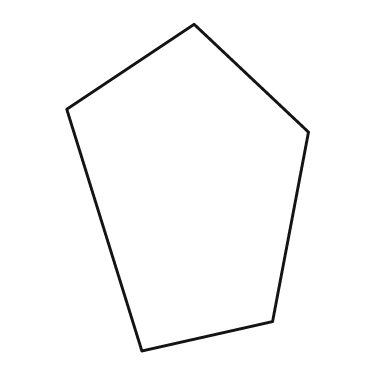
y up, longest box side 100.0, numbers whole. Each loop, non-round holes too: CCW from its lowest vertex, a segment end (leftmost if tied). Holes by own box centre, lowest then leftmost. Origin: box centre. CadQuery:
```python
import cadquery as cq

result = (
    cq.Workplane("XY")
    .moveTo(-14.0, -50.0)
    .lineTo(26.0, -41.0)
    .lineTo(37.0, 17.0)
    .lineTo(2.0, 50.0)
    .lineTo(-37.0, 24.0)
    .close()
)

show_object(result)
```